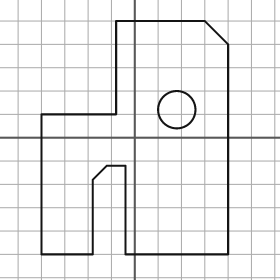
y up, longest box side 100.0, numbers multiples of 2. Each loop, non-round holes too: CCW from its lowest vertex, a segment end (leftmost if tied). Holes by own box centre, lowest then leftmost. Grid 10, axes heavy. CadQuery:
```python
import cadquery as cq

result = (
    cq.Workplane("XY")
    .moveTo(-40.0, -50.0)
    .lineTo(-18.0, -50.0)
    .lineTo(-18.0, -18.0)
    .lineTo(-12.0, -12.0)
    .lineTo(-4.0, -12.0)
    .lineTo(-4.0, -50.0)
    .lineTo(40.0, -50.0)
    .lineTo(40.0, 40.0)
    .lineTo(30.0, 50.0)
    .lineTo(-8.0, 50.0)
    .lineTo(-8.0, 10.0)
    .lineTo(-40.0, 10.0)
    .close()
    .moveTo(18.0, 12.0)
    .circle(8.0)
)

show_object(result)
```